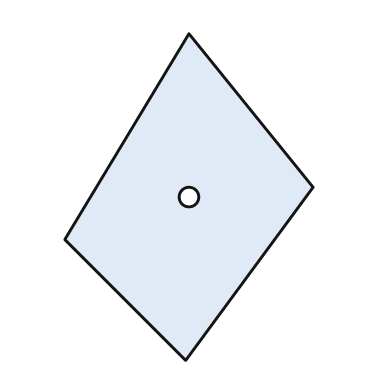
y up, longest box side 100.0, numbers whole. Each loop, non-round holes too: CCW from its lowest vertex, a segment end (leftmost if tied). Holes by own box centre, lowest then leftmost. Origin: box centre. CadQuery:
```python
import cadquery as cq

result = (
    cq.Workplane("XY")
    .moveTo(-1.0, -50.0)
    .lineTo(38.0, 3.0)
    .lineTo(0.0, 50.0)
    .lineTo(-38.0, -13.0)
    .close()
    .moveTo(0.0, 0.0)
    .circle(3.0)
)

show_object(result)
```